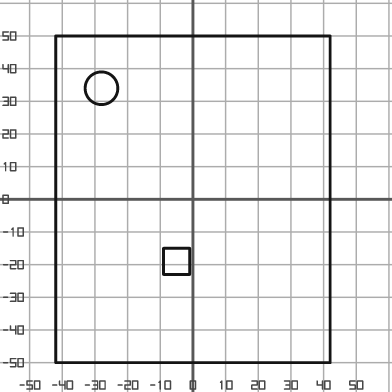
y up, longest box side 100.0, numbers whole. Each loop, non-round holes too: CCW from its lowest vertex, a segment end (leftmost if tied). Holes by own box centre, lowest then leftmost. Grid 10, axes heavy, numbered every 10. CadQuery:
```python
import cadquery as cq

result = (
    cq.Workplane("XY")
    .moveTo(-42.0, -50.0)
    .lineTo(42.0, -50.0)
    .lineTo(42.0, 50.0)
    .lineTo(-42.0, 50.0)
    .close()
    .moveTo(-9.0, -23.0)
    .lineTo(-1.0, -23.0)
    .lineTo(-1.0, -15.0)
    .lineTo(-9.0, -15.0)
    .close()
    .moveTo(-28.0, 34.0)
    .circle(5.0)
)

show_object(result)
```